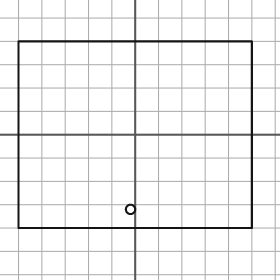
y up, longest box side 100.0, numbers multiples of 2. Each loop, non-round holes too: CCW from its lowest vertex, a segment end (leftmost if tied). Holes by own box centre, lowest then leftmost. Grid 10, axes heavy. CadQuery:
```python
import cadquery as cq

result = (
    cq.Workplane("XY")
    .moveTo(-50.0, -40.0)
    .lineTo(50.0, -40.0)
    .lineTo(50.0, 40.0)
    .lineTo(-50.0, 40.0)
    .close()
    .moveTo(-2.0, -32.0)
    .circle(2.0)
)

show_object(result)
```